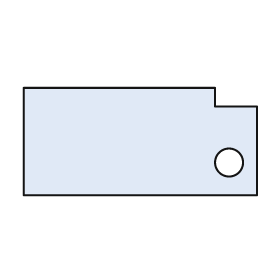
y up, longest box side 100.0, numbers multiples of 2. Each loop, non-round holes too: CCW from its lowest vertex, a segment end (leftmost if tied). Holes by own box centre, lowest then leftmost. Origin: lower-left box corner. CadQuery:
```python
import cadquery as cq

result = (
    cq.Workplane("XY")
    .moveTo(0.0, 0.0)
    .lineTo(100.0, 0.0)
    .lineTo(100.0, 38.0)
    .lineTo(82.0, 38.0)
    .lineTo(82.0, 46.0)
    .lineTo(0.0, 46.0)
    .close()
    .moveTo(88.0, 14.0)
    .circle(6.0)
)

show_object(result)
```